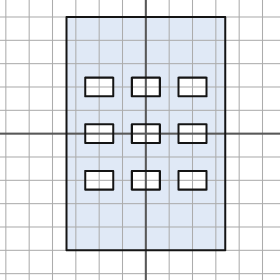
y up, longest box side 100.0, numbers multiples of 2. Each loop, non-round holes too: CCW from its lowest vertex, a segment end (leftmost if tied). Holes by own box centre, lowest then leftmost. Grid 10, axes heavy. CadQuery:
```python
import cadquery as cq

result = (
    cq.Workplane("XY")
    .moveTo(-34.0, -50.0)
    .lineTo(34.0, -50.0)
    .lineTo(34.0, 50.0)
    .lineTo(-34.0, 50.0)
    .close()
    .moveTo(-26.0, -24.0)
    .lineTo(-14.0, -24.0)
    .lineTo(-14.0, -16.0)
    .lineTo(-26.0, -16.0)
    .close()
    .moveTo(-6.0, -24.0)
    .lineTo(6.0, -24.0)
    .lineTo(6.0, -16.0)
    .lineTo(-6.0, -16.0)
    .close()
    .moveTo(14.0, -24.0)
    .lineTo(26.0, -24.0)
    .lineTo(26.0, -16.0)
    .lineTo(14.0, -16.0)
    .close()
    .moveTo(-26.0, -4.0)
    .lineTo(-14.0, -4.0)
    .lineTo(-14.0, 4.0)
    .lineTo(-26.0, 4.0)
    .close()
    .moveTo(-6.0, -4.0)
    .lineTo(6.0, -4.0)
    .lineTo(6.0, 4.0)
    .lineTo(-6.0, 4.0)
    .close()
    .moveTo(14.0, -4.0)
    .lineTo(26.0, -4.0)
    .lineTo(26.0, 4.0)
    .lineTo(14.0, 4.0)
    .close()
    .moveTo(-26.0, 16.0)
    .lineTo(-14.0, 16.0)
    .lineTo(-14.0, 24.0)
    .lineTo(-26.0, 24.0)
    .close()
    .moveTo(-6.0, 16.0)
    .lineTo(6.0, 16.0)
    .lineTo(6.0, 24.0)
    .lineTo(-6.0, 24.0)
    .close()
    .moveTo(14.0, 16.0)
    .lineTo(26.0, 16.0)
    .lineTo(26.0, 24.0)
    .lineTo(14.0, 24.0)
    .close()
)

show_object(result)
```